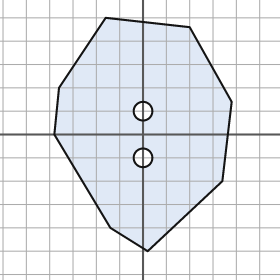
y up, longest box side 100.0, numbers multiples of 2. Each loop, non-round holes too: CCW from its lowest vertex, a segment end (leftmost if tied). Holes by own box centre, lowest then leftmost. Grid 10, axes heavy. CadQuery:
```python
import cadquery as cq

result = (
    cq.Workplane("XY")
    .moveTo(2.0, -50.0)
    .lineTo(34.0, -20.0)
    .lineTo(38.0, 14.0)
    .lineTo(20.0, 46.0)
    .lineTo(-16.0, 50.0)
    .lineTo(-36.0, 20.0)
    .lineTo(-38.0, 0.0)
    .lineTo(-14.0, -40.0)
    .close()
    .moveTo(0.0, -10.0)
    .circle(4.0)
    .moveTo(0.0, 10.0)
    .circle(4.0)
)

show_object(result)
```